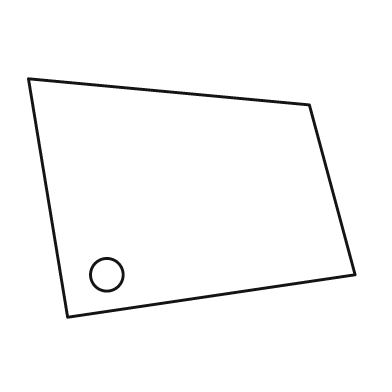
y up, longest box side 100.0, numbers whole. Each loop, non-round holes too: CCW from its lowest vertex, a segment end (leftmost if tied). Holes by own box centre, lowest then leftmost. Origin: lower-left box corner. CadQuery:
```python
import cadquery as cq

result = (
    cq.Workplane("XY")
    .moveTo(12.0, 0.0)
    .lineTo(100.0, 13.0)
    .lineTo(86.0, 65.0)
    .lineTo(0.0, 73.0)
    .close()
    .moveTo(24.0, 13.0)
    .circle(5.0)
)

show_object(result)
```